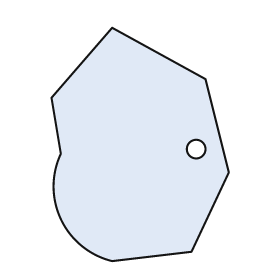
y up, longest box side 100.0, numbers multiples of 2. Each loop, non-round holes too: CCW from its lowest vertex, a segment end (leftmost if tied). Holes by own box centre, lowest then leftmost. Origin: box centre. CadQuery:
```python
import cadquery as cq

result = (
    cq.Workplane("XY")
    .moveTo(-12.0, -50.0)
    .lineTo(22.0, -46.0)
    .lineTo(38.0, -12.0)
    .lineTo(28.0, 28.0)
    .lineTo(-12.0, 50.0)
    .lineTo(-38.0, 20.0)
    .lineTo(-34.0, -4.0)
    .threePointArc((-34.0, -32.0), (-12.0, -50.0))
    .close()
    .moveTo(24.0, -2.0)
    .circle(4.0)
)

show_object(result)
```